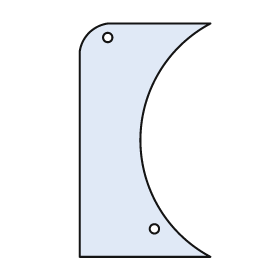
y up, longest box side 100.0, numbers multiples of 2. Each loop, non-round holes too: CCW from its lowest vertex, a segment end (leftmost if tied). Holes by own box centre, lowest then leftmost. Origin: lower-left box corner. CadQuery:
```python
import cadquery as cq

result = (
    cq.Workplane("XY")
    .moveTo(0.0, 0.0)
    .lineTo(56.0, 0.0)
    .threePointArc((26.0, 50.0), (56.0, 100.0))
    .lineTo(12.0, 100.0)
    .threePointArc((4.0, 96.0), (0.0, 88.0))
    .close()
    .moveTo(32.0, 12.0)
    .circle(2.0)
    .moveTo(12.0, 94.0)
    .circle(2.0)
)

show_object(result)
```